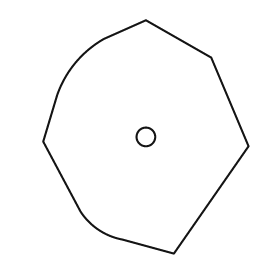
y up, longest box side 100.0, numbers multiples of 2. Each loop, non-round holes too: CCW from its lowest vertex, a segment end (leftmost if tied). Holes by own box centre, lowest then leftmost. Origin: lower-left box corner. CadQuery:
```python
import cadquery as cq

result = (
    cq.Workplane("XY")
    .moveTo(56.0, 0.0)
    .lineTo(88.0, 46.0)
    .lineTo(72.0, 84.0)
    .lineTo(44.0, 100.0)
    .lineTo(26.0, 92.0)
    .threePointArc((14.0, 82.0), (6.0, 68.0))
    .lineTo(0.0, 48.0)
    .lineTo(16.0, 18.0)
    .threePointArc((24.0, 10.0), (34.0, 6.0))
    .close()
    .moveTo(44.0, 50.0)
    .circle(4.0)
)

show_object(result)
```